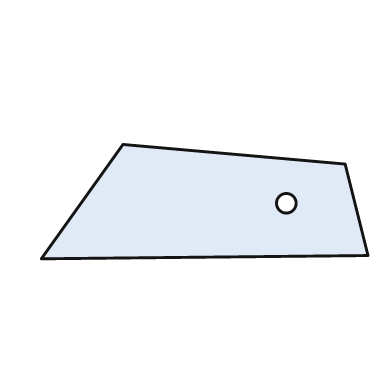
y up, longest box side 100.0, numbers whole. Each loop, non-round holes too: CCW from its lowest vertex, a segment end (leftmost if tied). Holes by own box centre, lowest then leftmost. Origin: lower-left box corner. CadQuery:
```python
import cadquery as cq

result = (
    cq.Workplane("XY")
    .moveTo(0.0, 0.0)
    .lineTo(100.0, 1.0)
    .lineTo(93.0, 29.0)
    .lineTo(25.0, 35.0)
    .close()
    .moveTo(75.0, 17.0)
    .circle(3.0)
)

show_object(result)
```